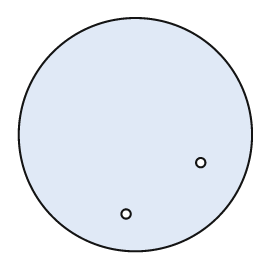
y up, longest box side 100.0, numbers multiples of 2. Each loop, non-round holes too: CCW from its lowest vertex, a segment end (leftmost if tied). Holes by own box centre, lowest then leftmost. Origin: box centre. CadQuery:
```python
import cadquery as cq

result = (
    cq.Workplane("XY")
    .moveTo(0.0, 0.0)
    .circle(50.0)
    .moveTo(-4.0, -34.0)
    .circle(2.0)
    .moveTo(28.0, -12.0)
    .circle(2.0)
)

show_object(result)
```